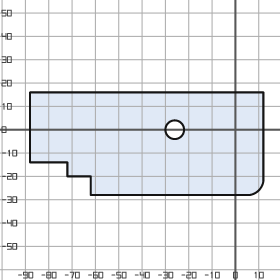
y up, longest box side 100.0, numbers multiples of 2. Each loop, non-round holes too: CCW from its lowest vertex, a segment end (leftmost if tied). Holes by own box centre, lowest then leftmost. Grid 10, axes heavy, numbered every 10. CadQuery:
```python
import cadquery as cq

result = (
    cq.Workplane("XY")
    .moveTo(-62.0, -28.0)
    .lineTo(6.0, -28.0)
    .threePointArc((10.0, -26.0), (12.0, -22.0))
    .lineTo(12.0, 16.0)
    .lineTo(-88.0, 16.0)
    .lineTo(-88.0, -14.0)
    .lineTo(-72.0, -14.0)
    .lineTo(-72.0, -20.0)
    .lineTo(-62.0, -20.0)
    .close()
    .moveTo(-26.0, 0.0)
    .circle(4.0)
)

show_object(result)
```